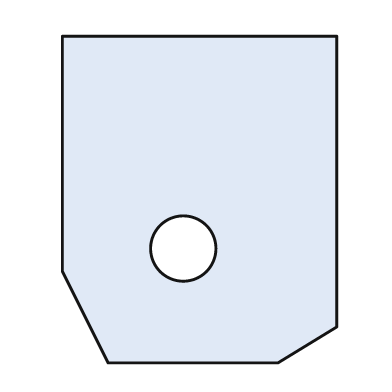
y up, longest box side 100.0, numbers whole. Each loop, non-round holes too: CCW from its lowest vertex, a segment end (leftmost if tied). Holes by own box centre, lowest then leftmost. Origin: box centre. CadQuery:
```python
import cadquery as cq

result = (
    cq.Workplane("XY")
    .moveTo(-28.0, -50.0)
    .lineTo(24.0, -50.0)
    .lineTo(42.0, -39.0)
    .lineTo(42.0, 50.0)
    .lineTo(-42.0, 50.0)
    .lineTo(-42.0, -22.0)
    .close()
    .moveTo(-5.0, -15.0)
    .circle(10.0)
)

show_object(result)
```